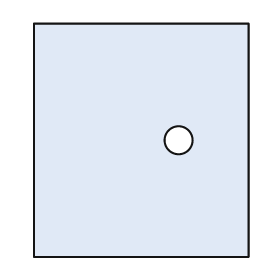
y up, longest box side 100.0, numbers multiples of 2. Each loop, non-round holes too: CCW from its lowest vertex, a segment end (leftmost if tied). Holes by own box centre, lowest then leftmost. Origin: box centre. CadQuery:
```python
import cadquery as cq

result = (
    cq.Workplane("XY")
    .moveTo(-46.0, -50.0)
    .lineTo(46.0, -50.0)
    .lineTo(46.0, 50.0)
    .lineTo(-46.0, 50.0)
    .close()
    .moveTo(16.0, 0.0)
    .circle(6.0)
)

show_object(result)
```